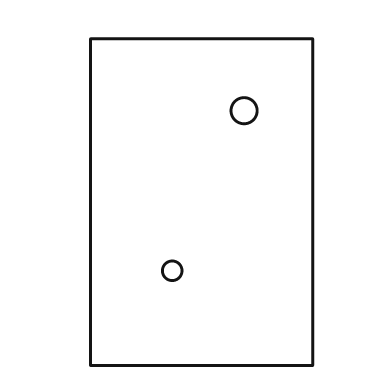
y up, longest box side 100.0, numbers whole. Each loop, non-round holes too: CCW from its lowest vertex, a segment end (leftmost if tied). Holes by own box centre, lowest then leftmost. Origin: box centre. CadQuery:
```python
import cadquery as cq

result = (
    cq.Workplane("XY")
    .moveTo(-34.0, -50.0)
    .lineTo(34.0, -50.0)
    .lineTo(34.0, 50.0)
    .lineTo(-34.0, 50.0)
    .close()
    .moveTo(-9.0, -21.0)
    .circle(3.0)
    .moveTo(13.0, 28.0)
    .circle(4.0)
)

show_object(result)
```